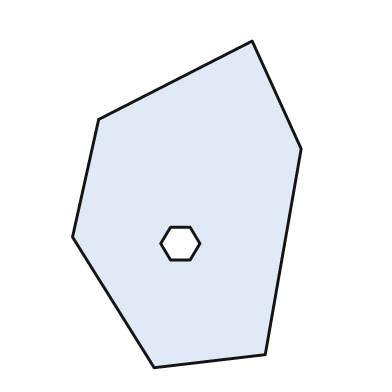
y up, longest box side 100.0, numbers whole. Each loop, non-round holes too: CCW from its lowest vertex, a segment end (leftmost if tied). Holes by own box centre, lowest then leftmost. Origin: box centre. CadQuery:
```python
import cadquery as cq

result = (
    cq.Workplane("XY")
    .moveTo(-10.0, -50.0)
    .lineTo(24.0, -46.0)
    .lineTo(35.0, 17.0)
    .lineTo(20.0, 50.0)
    .lineTo(-27.0, 26.0)
    .lineTo(-35.0, -10.0)
    .close()
    .moveTo(-5.0, -17.0)
    .lineTo(1.0, -17.0)
    .lineTo(4.0, -12.0)
    .lineTo(1.0, -7.0)
    .lineTo(-5.0, -7.0)
    .lineTo(-8.0, -12.0)
    .close()
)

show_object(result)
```